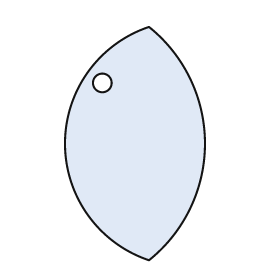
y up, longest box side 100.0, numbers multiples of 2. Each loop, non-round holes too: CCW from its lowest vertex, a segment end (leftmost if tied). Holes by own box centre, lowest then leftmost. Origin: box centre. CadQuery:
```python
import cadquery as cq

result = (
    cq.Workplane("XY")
    .moveTo(6.0, -50.0)
    .threePointArc((30.0, 0.0), (6.0, 50.0))
    .threePointArc((-30.0, 0.0), (6.0, -50.0))
    .close()
    .moveTo(-14.0, 26.0)
    .circle(4.0)
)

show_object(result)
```